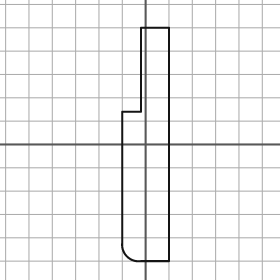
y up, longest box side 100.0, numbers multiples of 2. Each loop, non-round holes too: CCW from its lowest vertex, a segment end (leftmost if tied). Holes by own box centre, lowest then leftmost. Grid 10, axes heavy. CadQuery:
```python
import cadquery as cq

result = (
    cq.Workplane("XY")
    .moveTo(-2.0, -50.0)
    .lineTo(10.0, -50.0)
    .lineTo(10.0, 50.0)
    .lineTo(-2.0, 50.0)
    .lineTo(-2.0, 14.0)
    .lineTo(-10.0, 14.0)
    .lineTo(-10.0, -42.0)
    .threePointArc((-8.0, -48.0), (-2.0, -50.0))
    .close()
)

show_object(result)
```